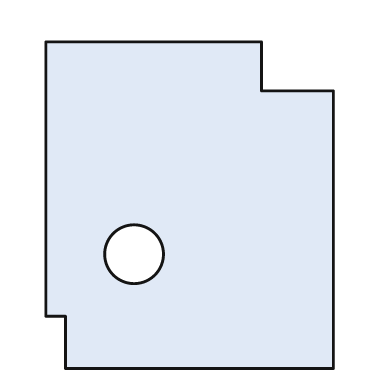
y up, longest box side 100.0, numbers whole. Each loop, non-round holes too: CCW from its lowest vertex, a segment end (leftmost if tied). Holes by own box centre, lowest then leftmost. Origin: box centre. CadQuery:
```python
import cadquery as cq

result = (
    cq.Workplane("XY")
    .moveTo(-38.0, -50.0)
    .lineTo(44.0, -50.0)
    .lineTo(44.0, 35.0)
    .lineTo(22.0, 35.0)
    .lineTo(22.0, 50.0)
    .lineTo(-44.0, 50.0)
    .lineTo(-44.0, -34.0)
    .lineTo(-38.0, -34.0)
    .close()
    .moveTo(-17.0, -15.0)
    .circle(9.0)
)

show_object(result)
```